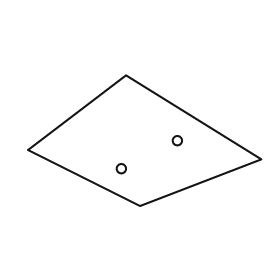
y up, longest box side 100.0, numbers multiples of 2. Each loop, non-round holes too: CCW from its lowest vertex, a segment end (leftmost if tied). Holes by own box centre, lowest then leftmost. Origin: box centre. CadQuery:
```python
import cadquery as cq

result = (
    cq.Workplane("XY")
    .moveTo(-2.0, -28.0)
    .lineTo(50.0, -8.0)
    .lineTo(-8.0, 28.0)
    .lineTo(-50.0, -4.0)
    .close()
    .moveTo(-10.0, -12.0)
    .circle(2.0)
    .moveTo(14.0, 0.0)
    .circle(2.0)
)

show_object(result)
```